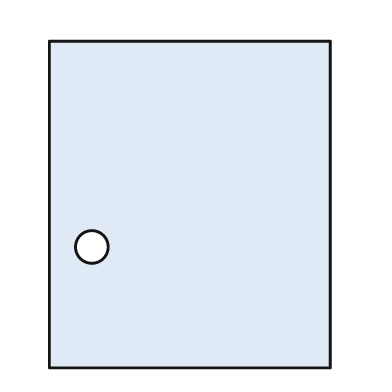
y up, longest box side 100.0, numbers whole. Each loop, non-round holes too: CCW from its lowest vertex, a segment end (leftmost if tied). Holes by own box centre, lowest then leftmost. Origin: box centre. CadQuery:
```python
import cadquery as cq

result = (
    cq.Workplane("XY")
    .moveTo(-43.0, -50.0)
    .lineTo(43.0, -50.0)
    .lineTo(43.0, 50.0)
    .lineTo(-43.0, 50.0)
    .close()
    .moveTo(-30.0, -13.0)
    .circle(5.0)
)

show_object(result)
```